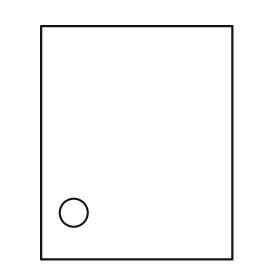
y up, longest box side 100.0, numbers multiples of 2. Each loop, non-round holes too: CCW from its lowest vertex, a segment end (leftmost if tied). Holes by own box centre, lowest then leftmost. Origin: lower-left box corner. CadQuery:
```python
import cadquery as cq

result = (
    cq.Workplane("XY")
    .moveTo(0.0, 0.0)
    .lineTo(82.0, 0.0)
    .lineTo(82.0, 100.0)
    .lineTo(0.0, 100.0)
    .close()
    .moveTo(14.0, 20.0)
    .circle(6.0)
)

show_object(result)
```